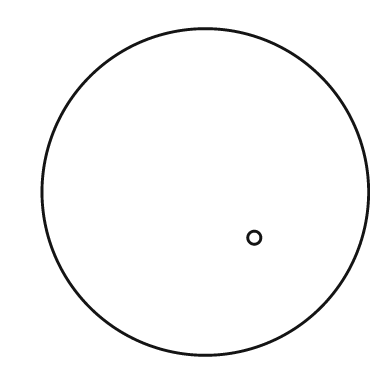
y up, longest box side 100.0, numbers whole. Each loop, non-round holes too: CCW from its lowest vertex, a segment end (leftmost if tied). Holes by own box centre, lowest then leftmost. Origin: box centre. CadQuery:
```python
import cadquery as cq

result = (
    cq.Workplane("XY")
    .moveTo(0.0, 0.0)
    .circle(50.0)
    .moveTo(15.0, -14.0)
    .circle(2.0)
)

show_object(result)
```